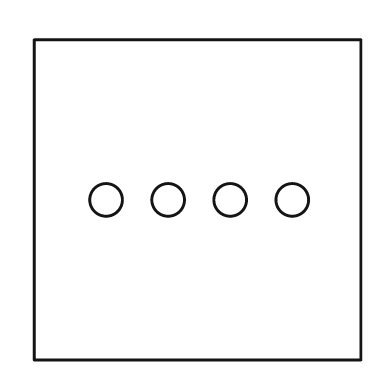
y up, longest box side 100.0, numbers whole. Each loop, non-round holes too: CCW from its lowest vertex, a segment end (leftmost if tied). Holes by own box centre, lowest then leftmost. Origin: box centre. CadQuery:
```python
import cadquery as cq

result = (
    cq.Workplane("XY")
    .moveTo(-50.0, -49.0)
    .lineTo(50.0, -49.0)
    .lineTo(50.0, 49.0)
    .lineTo(-50.0, 49.0)
    .close()
    .moveTo(-28.0, 0.0)
    .circle(5.0)
    .moveTo(-9.0, 0.0)
    .circle(5.0)
    .moveTo(10.0, 0.0)
    .circle(5.0)
    .moveTo(29.0, 0.0)
    .circle(5.0)
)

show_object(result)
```